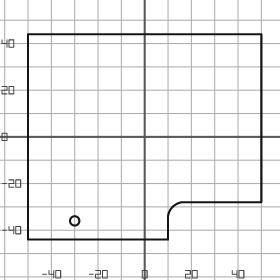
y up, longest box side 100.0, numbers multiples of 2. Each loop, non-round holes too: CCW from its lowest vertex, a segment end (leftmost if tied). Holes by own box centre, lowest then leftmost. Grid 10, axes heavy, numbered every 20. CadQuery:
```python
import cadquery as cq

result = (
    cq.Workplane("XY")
    .moveTo(-50.0, -44.0)
    .lineTo(10.0, -44.0)
    .lineTo(10.0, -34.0)
    .threePointArc((12.0, -30.0), (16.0, -28.0))
    .lineTo(50.0, -28.0)
    .lineTo(50.0, 44.0)
    .lineTo(-50.0, 44.0)
    .close()
    .moveTo(-30.0, -36.0)
    .circle(2.0)
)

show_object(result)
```